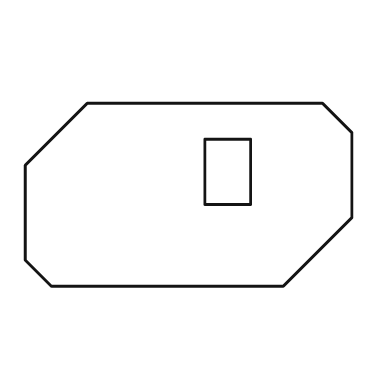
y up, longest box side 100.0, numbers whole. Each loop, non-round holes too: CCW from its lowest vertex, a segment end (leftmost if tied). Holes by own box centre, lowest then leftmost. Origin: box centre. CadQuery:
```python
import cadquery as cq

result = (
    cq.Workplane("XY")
    .moveTo(-42.0, -28.0)
    .lineTo(29.0, -28.0)
    .lineTo(50.0, -7.0)
    .lineTo(50.0, 19.0)
    .lineTo(41.0, 28.0)
    .lineTo(-31.0, 28.0)
    .lineTo(-50.0, 9.0)
    .lineTo(-50.0, -20.0)
    .close()
    .moveTo(5.0, -3.0)
    .lineTo(19.0, -3.0)
    .lineTo(19.0, 17.0)
    .lineTo(5.0, 17.0)
    .close()
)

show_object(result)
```